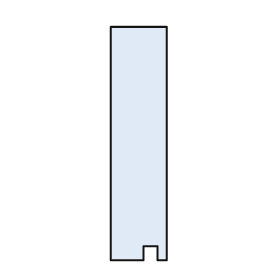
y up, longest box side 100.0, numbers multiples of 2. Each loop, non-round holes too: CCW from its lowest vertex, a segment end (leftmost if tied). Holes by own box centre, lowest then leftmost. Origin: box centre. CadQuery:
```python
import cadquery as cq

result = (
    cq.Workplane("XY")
    .moveTo(-12.0, -50.0)
    .lineTo(2.0, -50.0)
    .lineTo(2.0, -44.0)
    .lineTo(8.0, -44.0)
    .lineTo(8.0, -50.0)
    .lineTo(12.0, -50.0)
    .lineTo(12.0, 50.0)
    .lineTo(-12.0, 50.0)
    .close()
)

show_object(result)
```